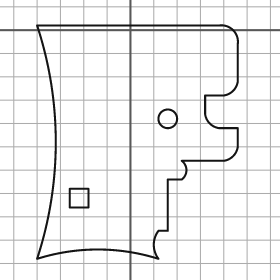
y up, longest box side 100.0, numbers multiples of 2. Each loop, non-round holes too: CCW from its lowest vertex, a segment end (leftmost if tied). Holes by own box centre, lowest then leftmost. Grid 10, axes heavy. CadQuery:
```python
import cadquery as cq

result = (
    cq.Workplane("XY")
    .moveTo(-40.0, -98.0)
    .threePointArc((-14.0, -94.0), (12.0, -98.0))
    .threePointArc((10.0, -92.0), (12.0, -86.0))
    .lineTo(16.0, -86.0)
    .lineTo(16.0, -64.0)
    .lineTo(22.0, -64.0)
    .threePointArc((24.0, -60.0), (22.0, -56.0))
    .lineTo(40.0, -56.0)
    .threePointArc((44.0, -54.0), (46.0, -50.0))
    .lineTo(46.0, -42.0)
    .lineTo(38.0, -42.0)
    .threePointArc((34.0, -40.0), (32.0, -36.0))
    .lineTo(32.0, -28.0)
    .lineTo(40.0, -28.0)
    .threePointArc((44.0, -26.0), (46.0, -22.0))
    .lineTo(46.0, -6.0)
    .threePointArc((44.0, 0.0), (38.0, 2.0))
    .lineTo(-40.0, 2.0)
    .threePointArc((-32.0, -48.0), (-40.0, -98.0))
    .close()
    .moveTo(-26.0, -76.0)
    .lineTo(-18.0, -76.0)
    .lineTo(-18.0, -68.0)
    .lineTo(-26.0, -68.0)
    .close()
    .moveTo(16.0, -38.0)
    .circle(4.0)
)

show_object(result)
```